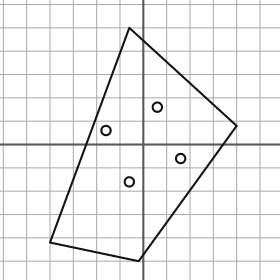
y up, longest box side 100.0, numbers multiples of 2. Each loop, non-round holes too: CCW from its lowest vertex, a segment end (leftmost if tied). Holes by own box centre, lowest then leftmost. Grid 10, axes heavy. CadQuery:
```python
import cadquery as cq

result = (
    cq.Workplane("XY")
    .moveTo(-2.0, -50.0)
    .lineTo(40.0, 8.0)
    .lineTo(-6.0, 50.0)
    .lineTo(-40.0, -42.0)
    .close()
    .moveTo(-6.0, -16.0)
    .circle(2.0)
    .moveTo(16.0, -6.0)
    .circle(2.0)
    .moveTo(-16.0, 6.0)
    .circle(2.0)
    .moveTo(6.0, 16.0)
    .circle(2.0)
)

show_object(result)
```